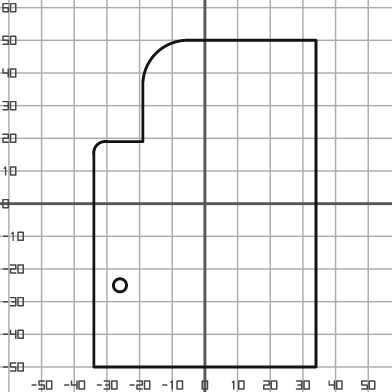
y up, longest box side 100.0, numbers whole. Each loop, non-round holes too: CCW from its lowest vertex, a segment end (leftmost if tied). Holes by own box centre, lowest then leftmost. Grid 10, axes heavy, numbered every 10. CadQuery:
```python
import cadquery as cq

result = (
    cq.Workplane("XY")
    .moveTo(-34.0, -50.0)
    .lineTo(34.0, -50.0)
    .lineTo(34.0, 50.0)
    .lineTo(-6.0, 50.0)
    .threePointArc((-15.0, 46.0), (-19.0, 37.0))
    .lineTo(-19.0, 19.0)
    .lineTo(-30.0, 19.0)
    .threePointArc((-33.0, 18.0), (-34.0, 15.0))
    .close()
    .moveTo(-26.0, -25.0)
    .circle(2.0)
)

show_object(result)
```